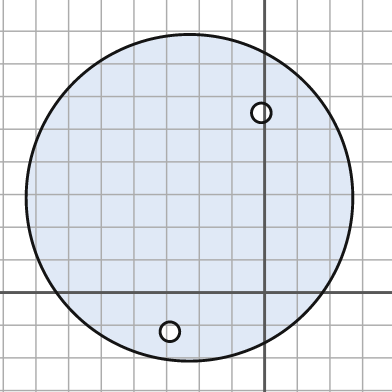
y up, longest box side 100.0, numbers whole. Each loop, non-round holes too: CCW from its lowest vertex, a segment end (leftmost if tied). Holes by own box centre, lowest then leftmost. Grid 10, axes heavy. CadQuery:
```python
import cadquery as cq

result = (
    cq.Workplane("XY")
    .moveTo(-23.0, 29.0)
    .circle(50.0)
    .moveTo(-29.0, -12.0)
    .circle(3.0)
    .moveTo(-1.0, 55.0)
    .circle(3.0)
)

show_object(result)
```